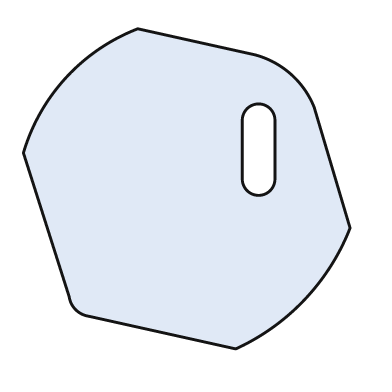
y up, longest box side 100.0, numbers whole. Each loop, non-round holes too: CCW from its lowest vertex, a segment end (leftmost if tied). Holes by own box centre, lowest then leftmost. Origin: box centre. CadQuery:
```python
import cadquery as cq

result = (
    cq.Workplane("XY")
    .moveTo(15.0, -49.0)
    .threePointArc((36.0, -34.0), (50.0, -12.0))
    .lineTo(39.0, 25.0)
    .threePointArc((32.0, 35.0), (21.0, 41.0))
    .lineTo(-15.0, 49.0)
    .threePointArc((-37.0, 34.0), (-50.0, 11.0))
    .lineTo(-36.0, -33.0)
    .threePointArc((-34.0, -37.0), (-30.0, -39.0))
    .close()
    .moveTo(17.0, 3.0)
    .threePointArc((22.0, -2.0), (27.0, 3.0))
    .lineTo(27.0, 21.0)
    .threePointArc((22.0, 26.0), (17.0, 21.0))
    .close()
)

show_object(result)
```